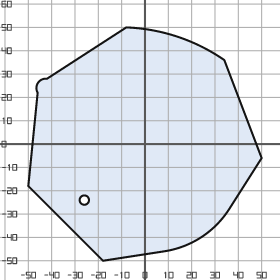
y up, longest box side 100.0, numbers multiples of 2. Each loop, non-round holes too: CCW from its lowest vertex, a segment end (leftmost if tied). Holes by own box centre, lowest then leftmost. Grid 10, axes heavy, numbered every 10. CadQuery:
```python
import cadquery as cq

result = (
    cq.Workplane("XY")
    .moveTo(-18.0, -50.0)
    .lineTo(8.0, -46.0)
    .threePointArc((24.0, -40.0), (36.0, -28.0))
    .lineTo(50.0, -6.0)
    .lineTo(34.0, 36.0)
    .threePointArc((14.0, 46.0), (-8.0, 50.0))
    .lineTo(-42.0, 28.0)
    .threePointArc((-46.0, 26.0), (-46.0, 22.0))
    .lineTo(-50.0, -18.0)
    .close()
    .moveTo(-26.0, -24.0)
    .circle(2.0)
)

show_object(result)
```